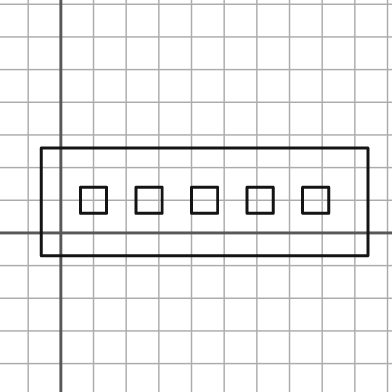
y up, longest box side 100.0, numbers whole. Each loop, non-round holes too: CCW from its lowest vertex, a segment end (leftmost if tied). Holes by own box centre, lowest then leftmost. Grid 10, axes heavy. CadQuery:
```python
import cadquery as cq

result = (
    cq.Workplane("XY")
    .moveTo(-6.0, -7.0)
    .lineTo(94.0, -7.0)
    .lineTo(94.0, 26.0)
    .lineTo(-6.0, 26.0)
    .close()
    .moveTo(6.0, 6.0)
    .lineTo(14.0, 6.0)
    .lineTo(14.0, 14.0)
    .lineTo(6.0, 14.0)
    .close()
    .moveTo(23.0, 6.0)
    .lineTo(31.0, 6.0)
    .lineTo(31.0, 14.0)
    .lineTo(23.0, 14.0)
    .close()
    .moveTo(40.0, 6.0)
    .lineTo(48.0, 6.0)
    .lineTo(48.0, 14.0)
    .lineTo(40.0, 14.0)
    .close()
    .moveTo(57.0, 6.0)
    .lineTo(65.0, 6.0)
    .lineTo(65.0, 14.0)
    .lineTo(57.0, 14.0)
    .close()
    .moveTo(74.0, 6.0)
    .lineTo(82.0, 6.0)
    .lineTo(82.0, 14.0)
    .lineTo(74.0, 14.0)
    .close()
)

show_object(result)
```